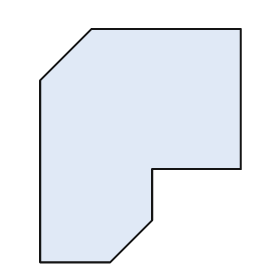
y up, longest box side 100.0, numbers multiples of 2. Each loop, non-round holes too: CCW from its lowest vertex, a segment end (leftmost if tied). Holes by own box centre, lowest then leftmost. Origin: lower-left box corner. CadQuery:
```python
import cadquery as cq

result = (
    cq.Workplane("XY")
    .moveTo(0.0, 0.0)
    .lineTo(30.0, 0.0)
    .lineTo(48.0, 18.0)
    .lineTo(48.0, 40.0)
    .lineTo(86.0, 40.0)
    .lineTo(86.0, 100.0)
    .lineTo(22.0, 100.0)
    .lineTo(0.0, 78.0)
    .close()
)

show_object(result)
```